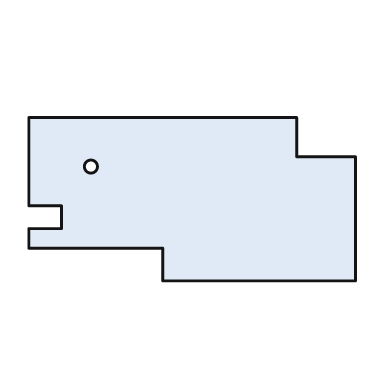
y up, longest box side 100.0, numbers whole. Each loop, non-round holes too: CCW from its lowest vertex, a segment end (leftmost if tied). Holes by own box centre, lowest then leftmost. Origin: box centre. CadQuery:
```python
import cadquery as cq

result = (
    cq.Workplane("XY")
    .moveTo(-9.0, -25.0)
    .lineTo(50.0, -25.0)
    .lineTo(50.0, 13.0)
    .lineTo(32.0, 13.0)
    .lineTo(32.0, 25.0)
    .lineTo(-50.0, 25.0)
    .lineTo(-50.0, -2.0)
    .lineTo(-40.0, -2.0)
    .lineTo(-40.0, -9.0)
    .lineTo(-50.0, -9.0)
    .lineTo(-50.0, -15.0)
    .lineTo(-9.0, -15.0)
    .close()
    .moveTo(-31.0, 10.0)
    .circle(2.0)
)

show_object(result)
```